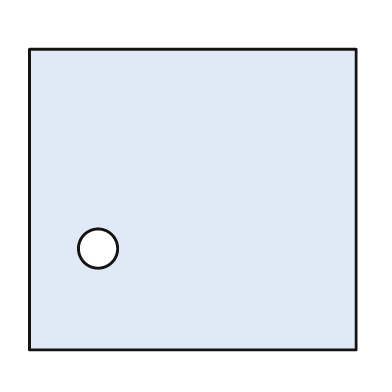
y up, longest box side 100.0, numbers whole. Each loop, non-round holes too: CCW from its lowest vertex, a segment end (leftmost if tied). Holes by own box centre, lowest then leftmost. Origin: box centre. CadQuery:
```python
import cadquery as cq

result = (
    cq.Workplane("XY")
    .moveTo(-50.0, -46.0)
    .lineTo(50.0, -46.0)
    .lineTo(50.0, 46.0)
    .lineTo(-50.0, 46.0)
    .close()
    .moveTo(-29.0, -15.0)
    .circle(6.0)
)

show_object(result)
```